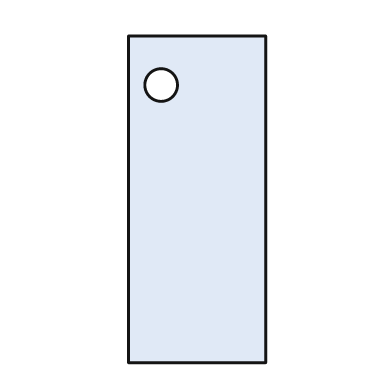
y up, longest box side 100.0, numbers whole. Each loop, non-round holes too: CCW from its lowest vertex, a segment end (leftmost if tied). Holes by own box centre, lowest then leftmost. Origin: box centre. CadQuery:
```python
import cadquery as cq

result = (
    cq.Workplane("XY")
    .moveTo(-21.0, -50.0)
    .lineTo(21.0, -50.0)
    .lineTo(21.0, 50.0)
    .lineTo(-21.0, 50.0)
    .close()
    .moveTo(-11.0, 35.0)
    .circle(5.0)
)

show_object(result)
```